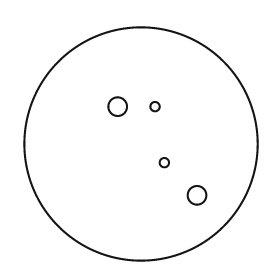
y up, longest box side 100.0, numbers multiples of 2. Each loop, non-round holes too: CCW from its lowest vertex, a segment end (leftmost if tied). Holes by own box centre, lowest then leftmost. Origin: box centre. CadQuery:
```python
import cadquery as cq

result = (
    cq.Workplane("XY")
    .moveTo(0.0, 0.0)
    .circle(50.0)
    .moveTo(24.0, -22.0)
    .circle(4.0)
    .moveTo(10.0, -8.0)
    .circle(2.0)
    .moveTo(-10.0, 16.0)
    .circle(4.0)
    .moveTo(6.0, 16.0)
    .circle(2.0)
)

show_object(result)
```